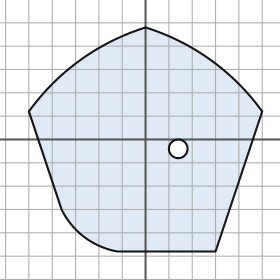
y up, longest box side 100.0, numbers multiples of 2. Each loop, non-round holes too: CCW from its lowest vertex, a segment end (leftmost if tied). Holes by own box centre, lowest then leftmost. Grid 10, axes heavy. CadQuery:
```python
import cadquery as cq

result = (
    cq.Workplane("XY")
    .moveTo(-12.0, -48.0)
    .lineTo(30.0, -48.0)
    .lineTo(50.0, 12.0)
    .threePointArc((28.0, 34.0), (0.0, 48.0))
    .threePointArc((-28.0, 34.0), (-50.0, 12.0))
    .lineTo(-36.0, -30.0)
    .threePointArc((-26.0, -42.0), (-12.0, -48.0))
    .close()
    .moveTo(14.0, -4.0)
    .circle(4.0)
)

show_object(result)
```